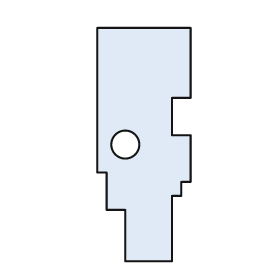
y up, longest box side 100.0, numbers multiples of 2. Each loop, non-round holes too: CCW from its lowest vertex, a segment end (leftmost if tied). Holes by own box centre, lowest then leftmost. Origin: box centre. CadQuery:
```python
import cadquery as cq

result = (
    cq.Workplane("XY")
    .moveTo(-8.0, -50.0)
    .lineTo(12.0, -50.0)
    .lineTo(12.0, -22.0)
    .lineTo(16.0, -22.0)
    .lineTo(16.0, -16.0)
    .lineTo(20.0, -16.0)
    .lineTo(20.0, 4.0)
    .lineTo(12.0, 4.0)
    .lineTo(12.0, 20.0)
    .lineTo(20.0, 20.0)
    .lineTo(20.0, 50.0)
    .lineTo(-20.0, 50.0)
    .lineTo(-20.0, -12.0)
    .lineTo(-16.0, -12.0)
    .lineTo(-16.0, -28.0)
    .lineTo(-8.0, -28.0)
    .close()
    .moveTo(-8.0, 0.0)
    .circle(6.0)
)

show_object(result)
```